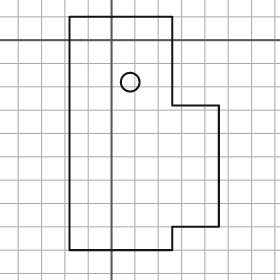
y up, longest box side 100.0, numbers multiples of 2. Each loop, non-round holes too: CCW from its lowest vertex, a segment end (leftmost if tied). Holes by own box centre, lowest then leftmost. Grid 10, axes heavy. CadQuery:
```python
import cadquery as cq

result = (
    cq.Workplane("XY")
    .moveTo(-18.0, -90.0)
    .lineTo(26.0, -90.0)
    .lineTo(26.0, -80.0)
    .lineTo(46.0, -80.0)
    .lineTo(46.0, -28.0)
    .lineTo(26.0, -28.0)
    .lineTo(26.0, 10.0)
    .lineTo(-18.0, 10.0)
    .close()
    .moveTo(8.0, -18.0)
    .circle(4.0)
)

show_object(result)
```